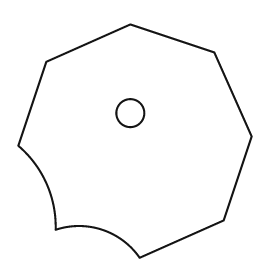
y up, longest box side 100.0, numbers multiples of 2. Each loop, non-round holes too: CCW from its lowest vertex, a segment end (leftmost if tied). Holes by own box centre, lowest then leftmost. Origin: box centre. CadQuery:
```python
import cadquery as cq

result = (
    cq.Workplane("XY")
    .moveTo(2.0, -50.0)
    .lineTo(38.0, -34.0)
    .lineTo(50.0, 2.0)
    .lineTo(34.0, 38.0)
    .lineTo(-2.0, 50.0)
    .lineTo(-38.0, 34.0)
    .lineTo(-50.0, -2.0)
    .threePointArc((-38.0, -18.0), (-34.0, -38.0))
    .threePointArc((-14.0, -38.0), (2.0, -50.0))
    .close()
    .moveTo(-2.0, 12.0)
    .circle(6.0)
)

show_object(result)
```